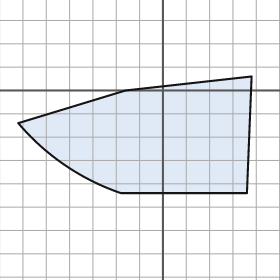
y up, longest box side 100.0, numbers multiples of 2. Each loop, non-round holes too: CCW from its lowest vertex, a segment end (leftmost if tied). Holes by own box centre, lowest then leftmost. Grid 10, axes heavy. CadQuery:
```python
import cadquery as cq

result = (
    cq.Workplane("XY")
    .moveTo(-18.0, -44.0)
    .lineTo(36.0, -44.0)
    .lineTo(38.0, 6.0)
    .lineTo(-16.0, 0.0)
    .lineTo(-62.0, -14.0)
    .threePointArc((-42.0, -32.0), (-18.0, -44.0))
    .close()
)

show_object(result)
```